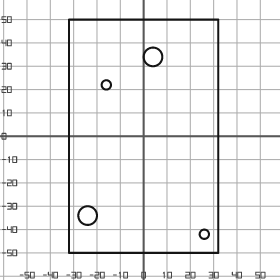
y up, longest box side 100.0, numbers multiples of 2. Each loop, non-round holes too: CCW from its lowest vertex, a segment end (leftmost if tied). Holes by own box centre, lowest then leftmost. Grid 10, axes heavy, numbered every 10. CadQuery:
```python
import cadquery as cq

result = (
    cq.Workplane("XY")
    .moveTo(-32.0, -50.0)
    .lineTo(32.0, -50.0)
    .lineTo(32.0, 50.0)
    .lineTo(-32.0, 50.0)
    .close()
    .moveTo(26.0, -42.0)
    .circle(2.0)
    .moveTo(-24.0, -34.0)
    .circle(4.0)
    .moveTo(-16.0, 22.0)
    .circle(2.0)
    .moveTo(4.0, 34.0)
    .circle(4.0)
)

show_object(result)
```